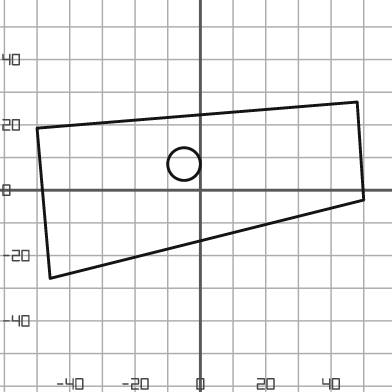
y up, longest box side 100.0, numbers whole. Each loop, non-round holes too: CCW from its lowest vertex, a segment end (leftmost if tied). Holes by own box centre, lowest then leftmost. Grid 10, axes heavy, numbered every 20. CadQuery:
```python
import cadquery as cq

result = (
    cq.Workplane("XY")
    .moveTo(-46.0, -27.0)
    .lineTo(50.0, -3.0)
    .lineTo(48.0, 27.0)
    .lineTo(-50.0, 19.0)
    .close()
    .moveTo(-5.0, 8.0)
    .circle(5.0)
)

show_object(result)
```